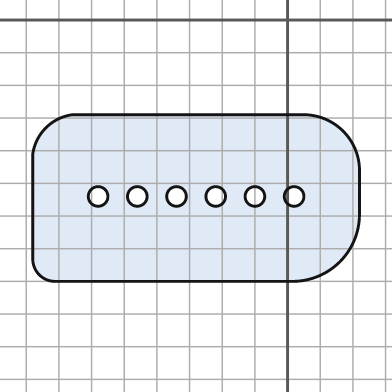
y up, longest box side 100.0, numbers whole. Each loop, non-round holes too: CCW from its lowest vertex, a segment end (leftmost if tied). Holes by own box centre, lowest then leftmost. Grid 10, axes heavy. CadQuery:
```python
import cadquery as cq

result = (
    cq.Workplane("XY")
    .moveTo(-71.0, -80.0)
    .lineTo(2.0, -80.0)
    .threePointArc((16.0, -74.0), (22.0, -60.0))
    .lineTo(22.0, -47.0)
    .threePointArc((17.0, -34.0), (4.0, -29.0))
    .lineTo(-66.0, -29.0)
    .threePointArc((-74.0, -33.0), (-78.0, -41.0))
    .lineTo(-78.0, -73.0)
    .threePointArc((-76.0, -78.0), (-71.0, -80.0))
    .close()
    .moveTo(-58.0, -54.0)
    .circle(3.0)
    .moveTo(-46.0, -54.0)
    .circle(3.0)
    .moveTo(-34.0, -54.0)
    .circle(3.0)
    .moveTo(-22.0, -54.0)
    .circle(3.0)
    .moveTo(-10.0, -54.0)
    .circle(3.0)
    .moveTo(2.0, -54.0)
    .circle(3.0)
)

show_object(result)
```